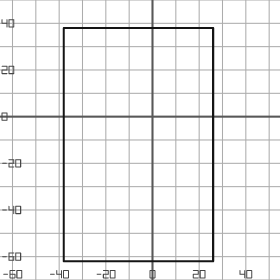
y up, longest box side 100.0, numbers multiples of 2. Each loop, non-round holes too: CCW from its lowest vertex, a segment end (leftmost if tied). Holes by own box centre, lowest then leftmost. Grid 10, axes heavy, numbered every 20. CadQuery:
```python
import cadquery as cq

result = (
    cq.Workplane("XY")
    .moveTo(-38.0, -62.0)
    .lineTo(26.0, -62.0)
    .lineTo(26.0, 38.0)
    .lineTo(-38.0, 38.0)
    .close()
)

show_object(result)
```